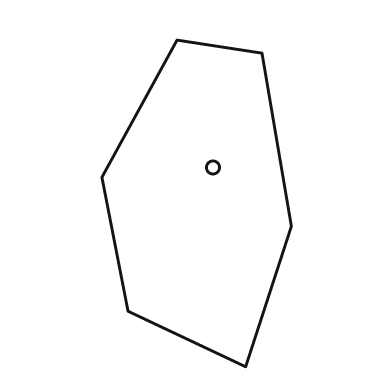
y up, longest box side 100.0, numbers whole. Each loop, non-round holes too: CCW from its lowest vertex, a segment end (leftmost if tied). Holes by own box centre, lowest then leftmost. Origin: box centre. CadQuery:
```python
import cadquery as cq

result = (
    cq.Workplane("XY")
    .moveTo(15.0, -50.0)
    .lineTo(29.0, -7.0)
    .lineTo(20.0, 46.0)
    .lineTo(-6.0, 50.0)
    .lineTo(-29.0, 8.0)
    .lineTo(-21.0, -33.0)
    .close()
    .moveTo(5.0, 11.0)
    .circle(2.0)
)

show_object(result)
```